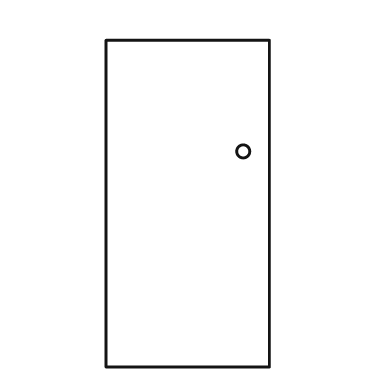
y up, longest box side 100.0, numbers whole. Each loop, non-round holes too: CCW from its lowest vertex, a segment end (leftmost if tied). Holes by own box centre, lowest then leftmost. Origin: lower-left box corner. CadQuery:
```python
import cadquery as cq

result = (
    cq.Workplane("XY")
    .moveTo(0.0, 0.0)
    .lineTo(50.0, 0.0)
    .lineTo(50.0, 100.0)
    .lineTo(0.0, 100.0)
    .close()
    .moveTo(42.0, 66.0)
    .circle(2.0)
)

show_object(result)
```